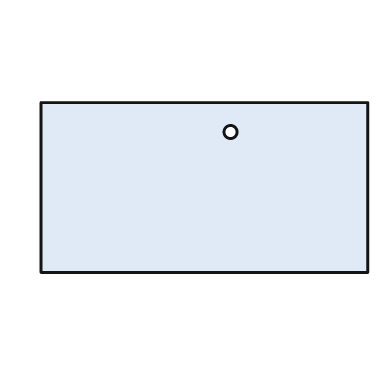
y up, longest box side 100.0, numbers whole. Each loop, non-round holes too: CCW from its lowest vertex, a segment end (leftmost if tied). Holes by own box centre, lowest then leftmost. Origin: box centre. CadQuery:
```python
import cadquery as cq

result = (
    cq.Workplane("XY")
    .moveTo(-50.0, -26.0)
    .lineTo(50.0, -26.0)
    .lineTo(50.0, 26.0)
    .lineTo(-50.0, 26.0)
    .close()
    .moveTo(8.0, 17.0)
    .circle(2.0)
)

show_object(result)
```